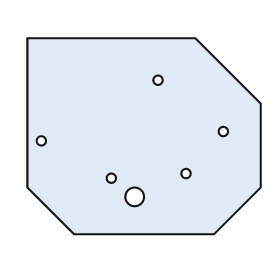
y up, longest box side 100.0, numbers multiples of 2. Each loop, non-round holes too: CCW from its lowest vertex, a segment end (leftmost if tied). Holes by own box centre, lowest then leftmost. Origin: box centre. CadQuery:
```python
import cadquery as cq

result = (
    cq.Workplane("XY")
    .moveTo(-30.0, -42.0)
    .lineTo(30.0, -42.0)
    .lineTo(50.0, -22.0)
    .lineTo(50.0, 14.0)
    .lineTo(22.0, 42.0)
    .lineTo(-50.0, 42.0)
    .lineTo(-50.0, -22.0)
    .close()
    .moveTo(-4.0, -26.0)
    .circle(4.0)
    .moveTo(-14.0, -18.0)
    .circle(2.0)
    .moveTo(18.0, -16.0)
    .circle(2.0)
    .moveTo(-44.0, -2.0)
    .circle(2.0)
    .moveTo(34.0, 2.0)
    .circle(2.0)
    .moveTo(6.0, 24.0)
    .circle(2.0)
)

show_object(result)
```